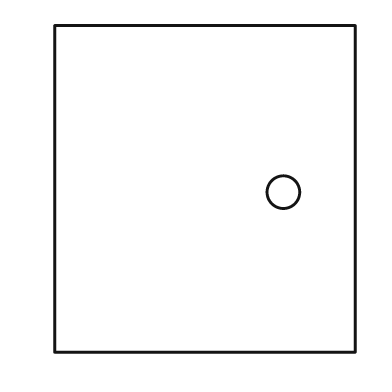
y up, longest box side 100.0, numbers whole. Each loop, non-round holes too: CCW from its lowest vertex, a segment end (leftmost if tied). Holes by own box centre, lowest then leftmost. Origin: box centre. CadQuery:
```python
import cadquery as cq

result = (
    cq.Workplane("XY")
    .moveTo(-46.0, -50.0)
    .lineTo(46.0, -50.0)
    .lineTo(46.0, 50.0)
    .lineTo(-46.0, 50.0)
    .close()
    .moveTo(24.0, -1.0)
    .circle(5.0)
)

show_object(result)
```